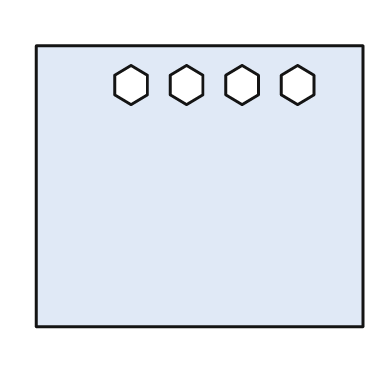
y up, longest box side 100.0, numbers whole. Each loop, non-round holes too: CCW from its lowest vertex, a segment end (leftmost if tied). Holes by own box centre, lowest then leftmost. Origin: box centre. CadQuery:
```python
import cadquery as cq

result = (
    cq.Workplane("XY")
    .moveTo(-50.0, -43.0)
    .lineTo(50.0, -43.0)
    .lineTo(50.0, 43.0)
    .lineTo(-50.0, 43.0)
    .close()
    .moveTo(-21.0, 25.0)
    .lineTo(-16.0, 28.0)
    .lineTo(-16.0, 34.0)
    .lineTo(-21.0, 37.0)
    .lineTo(-26.0, 34.0)
    .lineTo(-26.0, 28.0)
    .close()
    .moveTo(-4.0, 25.0)
    .lineTo(1.0, 28.0)
    .lineTo(1.0, 34.0)
    .lineTo(-4.0, 37.0)
    .lineTo(-9.0, 34.0)
    .lineTo(-9.0, 28.0)
    .close()
    .moveTo(13.0, 25.0)
    .lineTo(18.0, 28.0)
    .lineTo(18.0, 34.0)
    .lineTo(13.0, 37.0)
    .lineTo(8.0, 34.0)
    .lineTo(8.0, 28.0)
    .close()
    .moveTo(30.0, 25.0)
    .lineTo(35.0, 28.0)
    .lineTo(35.0, 34.0)
    .lineTo(30.0, 37.0)
    .lineTo(25.0, 34.0)
    .lineTo(25.0, 28.0)
    .close()
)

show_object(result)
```